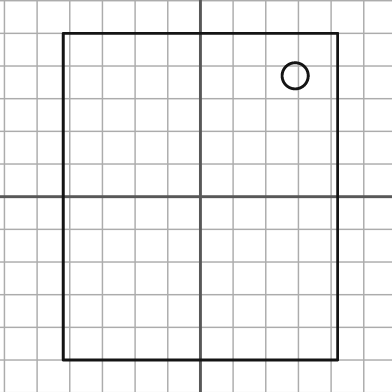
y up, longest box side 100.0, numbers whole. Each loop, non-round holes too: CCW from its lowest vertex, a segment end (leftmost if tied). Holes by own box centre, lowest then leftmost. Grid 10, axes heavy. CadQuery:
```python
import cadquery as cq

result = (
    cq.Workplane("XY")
    .moveTo(-42.0, -50.0)
    .lineTo(42.0, -50.0)
    .lineTo(42.0, 50.0)
    .lineTo(-42.0, 50.0)
    .close()
    .moveTo(29.0, 37.0)
    .circle(4.0)
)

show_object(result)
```